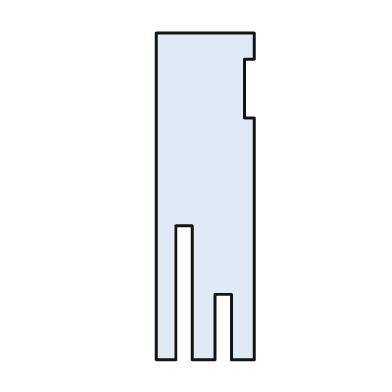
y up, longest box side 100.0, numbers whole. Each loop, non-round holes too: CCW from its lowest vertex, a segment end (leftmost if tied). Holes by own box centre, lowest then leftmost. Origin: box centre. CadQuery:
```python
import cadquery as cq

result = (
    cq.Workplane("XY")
    .moveTo(-15.0, -50.0)
    .lineTo(-9.0, -50.0)
    .lineTo(-9.0, -9.0)
    .lineTo(-4.0, -9.0)
    .lineTo(-4.0, -50.0)
    .lineTo(3.0, -50.0)
    .lineTo(3.0, -30.0)
    .lineTo(8.0, -30.0)
    .lineTo(8.0, -50.0)
    .lineTo(15.0, -50.0)
    .lineTo(15.0, 24.0)
    .lineTo(12.0, 24.0)
    .lineTo(12.0, 42.0)
    .lineTo(15.0, 42.0)
    .lineTo(15.0, 50.0)
    .lineTo(-15.0, 50.0)
    .close()
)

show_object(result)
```